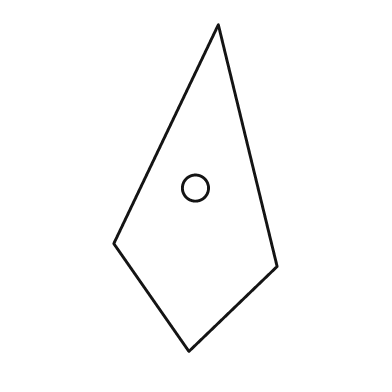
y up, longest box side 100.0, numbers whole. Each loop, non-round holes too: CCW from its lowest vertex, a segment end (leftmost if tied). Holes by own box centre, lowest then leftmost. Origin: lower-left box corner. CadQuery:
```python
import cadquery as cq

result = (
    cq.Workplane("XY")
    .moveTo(23.0, 0.0)
    .lineTo(50.0, 26.0)
    .lineTo(32.0, 100.0)
    .lineTo(0.0, 33.0)
    .close()
    .moveTo(25.0, 50.0)
    .circle(4.0)
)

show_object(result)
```